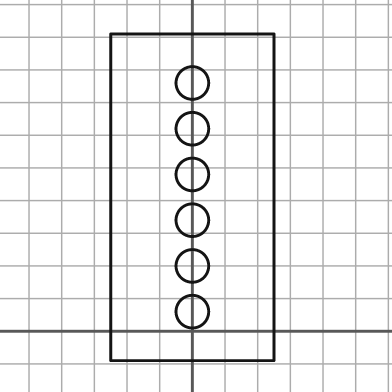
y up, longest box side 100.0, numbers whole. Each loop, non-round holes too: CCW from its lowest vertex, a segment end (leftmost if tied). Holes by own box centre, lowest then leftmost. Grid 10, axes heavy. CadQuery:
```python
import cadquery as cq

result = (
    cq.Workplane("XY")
    .moveTo(-25.0, -9.0)
    .lineTo(25.0, -9.0)
    .lineTo(25.0, 91.0)
    .lineTo(-25.0, 91.0)
    .close()
    .moveTo(0.0, 6.0)
    .circle(5.0)
    .moveTo(0.0, 20.0)
    .circle(5.0)
    .moveTo(0.0, 34.0)
    .circle(5.0)
    .moveTo(0.0, 48.0)
    .circle(5.0)
    .moveTo(0.0, 62.0)
    .circle(5.0)
    .moveTo(0.0, 76.0)
    .circle(5.0)
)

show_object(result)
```